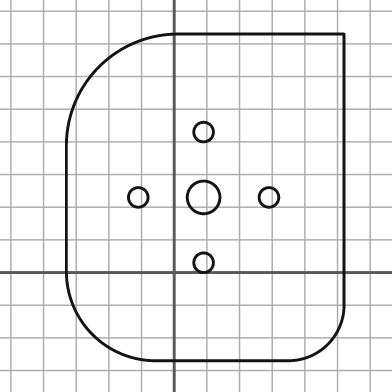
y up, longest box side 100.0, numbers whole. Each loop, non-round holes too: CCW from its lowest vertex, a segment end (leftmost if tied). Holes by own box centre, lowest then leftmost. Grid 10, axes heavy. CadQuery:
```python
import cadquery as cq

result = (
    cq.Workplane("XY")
    .moveTo(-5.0, -27.0)
    .lineTo(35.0, -27.0)
    .threePointArc((47.0, -22.0), (52.0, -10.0))
    .lineTo(52.0, 73.0)
    .lineTo(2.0, 73.0)
    .threePointArc((-23.0, 63.0), (-33.0, 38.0))
    .lineTo(-33.0, 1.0)
    .threePointArc((-25.0, -19.0), (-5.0, -27.0))
    .close()
    .moveTo(9.0, 3.0)
    .circle(3.0)
    .moveTo(-11.0, 23.0)
    .circle(3.0)
    .moveTo(9.0, 23.0)
    .circle(5.0)
    .moveTo(29.0, 23.0)
    .circle(3.0)
    .moveTo(9.0, 43.0)
    .circle(3.0)
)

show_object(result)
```